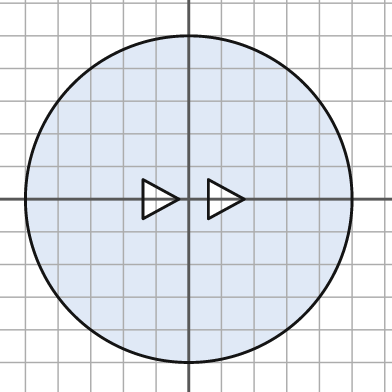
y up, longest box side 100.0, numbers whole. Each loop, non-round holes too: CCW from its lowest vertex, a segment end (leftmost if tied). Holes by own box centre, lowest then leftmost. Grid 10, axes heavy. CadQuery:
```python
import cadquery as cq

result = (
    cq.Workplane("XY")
    .moveTo(0.0, 0.0)
    .circle(50.0)
    .moveTo(-14.0, -6.0)
    .lineTo(-3.0, 0.0)
    .lineTo(-14.0, 6.0)
    .close()
    .moveTo(6.0, -6.0)
    .lineTo(17.0, 0.0)
    .lineTo(6.0, 6.0)
    .close()
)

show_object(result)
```